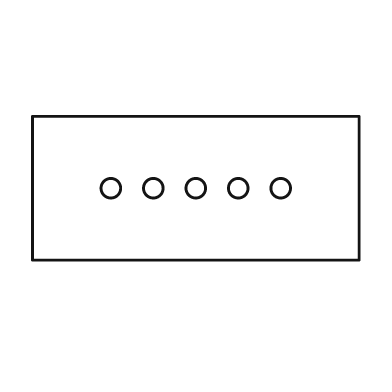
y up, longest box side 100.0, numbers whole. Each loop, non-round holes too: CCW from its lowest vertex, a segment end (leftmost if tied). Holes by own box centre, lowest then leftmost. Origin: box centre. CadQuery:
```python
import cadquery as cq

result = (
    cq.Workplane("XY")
    .moveTo(-50.0, -22.0)
    .lineTo(50.0, -22.0)
    .lineTo(50.0, 22.0)
    .lineTo(-50.0, 22.0)
    .close()
    .moveTo(-26.0, 0.0)
    .circle(3.0)
    .moveTo(-13.0, 0.0)
    .circle(3.0)
    .moveTo(0.0, 0.0)
    .circle(3.0)
    .moveTo(13.0, 0.0)
    .circle(3.0)
    .moveTo(26.0, 0.0)
    .circle(3.0)
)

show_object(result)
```